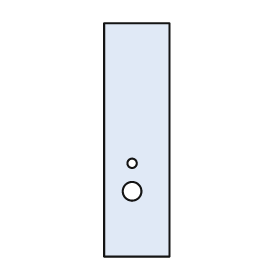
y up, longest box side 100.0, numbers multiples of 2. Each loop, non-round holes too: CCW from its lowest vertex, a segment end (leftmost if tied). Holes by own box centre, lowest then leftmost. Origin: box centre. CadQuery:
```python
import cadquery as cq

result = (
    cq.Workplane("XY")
    .moveTo(-14.0, -50.0)
    .lineTo(14.0, -50.0)
    .lineTo(14.0, 50.0)
    .lineTo(-14.0, 50.0)
    .close()
    .moveTo(-2.0, -22.0)
    .circle(4.0)
    .moveTo(-2.0, -10.0)
    .circle(2.0)
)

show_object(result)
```